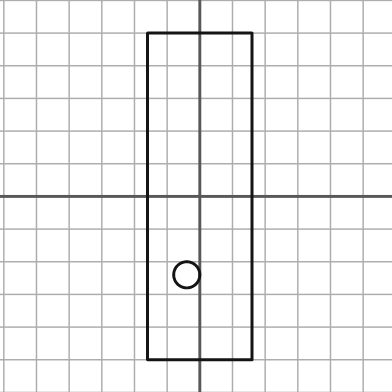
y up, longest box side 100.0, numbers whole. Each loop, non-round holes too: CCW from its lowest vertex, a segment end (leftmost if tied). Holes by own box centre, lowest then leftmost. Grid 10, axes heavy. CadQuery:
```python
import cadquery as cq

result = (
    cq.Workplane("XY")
    .moveTo(-16.0, -50.0)
    .lineTo(16.0, -50.0)
    .lineTo(16.0, 50.0)
    .lineTo(-16.0, 50.0)
    .close()
    .moveTo(-4.0, -24.0)
    .circle(4.0)
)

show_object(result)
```